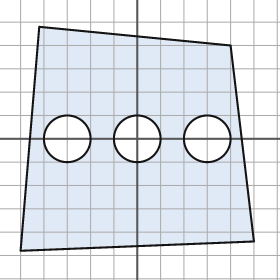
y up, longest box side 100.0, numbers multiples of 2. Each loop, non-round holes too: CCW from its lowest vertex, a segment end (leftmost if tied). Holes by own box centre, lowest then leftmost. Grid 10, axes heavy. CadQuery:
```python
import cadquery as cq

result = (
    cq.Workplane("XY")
    .moveTo(-50.0, -48.0)
    .lineTo(50.0, -44.0)
    .lineTo(40.0, 40.0)
    .lineTo(-42.0, 48.0)
    .close()
    .moveTo(-30.0, 0.0)
    .circle(10.0)
    .moveTo(0.0, 0.0)
    .circle(10.0)
    .moveTo(30.0, 0.0)
    .circle(10.0)
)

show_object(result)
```